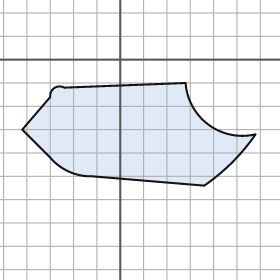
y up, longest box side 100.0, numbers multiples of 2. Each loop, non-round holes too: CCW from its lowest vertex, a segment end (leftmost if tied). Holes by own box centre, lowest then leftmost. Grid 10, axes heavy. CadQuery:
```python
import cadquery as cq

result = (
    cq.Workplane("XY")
    .moveTo(36.0, -54.0)
    .threePointArc((48.0, -44.0), (58.0, -32.0))
    .threePointArc((38.0, -28.0), (28.0, -10.0))
    .lineTo(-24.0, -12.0)
    .threePointArc((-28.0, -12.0), (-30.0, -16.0))
    .lineTo(-42.0, -30.0)
    .lineTo(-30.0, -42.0)
    .threePointArc((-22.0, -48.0), (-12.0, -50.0))
    .close()
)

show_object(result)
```